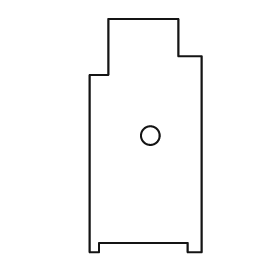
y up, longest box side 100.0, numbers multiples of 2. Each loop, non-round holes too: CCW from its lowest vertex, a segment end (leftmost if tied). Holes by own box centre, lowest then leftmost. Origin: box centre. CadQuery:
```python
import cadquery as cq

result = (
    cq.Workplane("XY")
    .moveTo(-24.0, -50.0)
    .lineTo(-20.0, -50.0)
    .lineTo(-20.0, -46.0)
    .lineTo(18.0, -46.0)
    .lineTo(18.0, -50.0)
    .lineTo(24.0, -50.0)
    .lineTo(24.0, 34.0)
    .lineTo(14.0, 34.0)
    .lineTo(14.0, 50.0)
    .lineTo(-16.0, 50.0)
    .lineTo(-16.0, 26.0)
    .lineTo(-24.0, 26.0)
    .close()
    .moveTo(2.0, 0.0)
    .circle(4.0)
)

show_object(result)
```